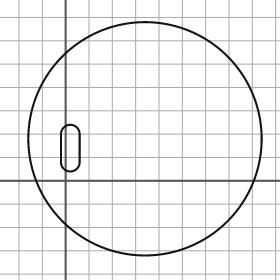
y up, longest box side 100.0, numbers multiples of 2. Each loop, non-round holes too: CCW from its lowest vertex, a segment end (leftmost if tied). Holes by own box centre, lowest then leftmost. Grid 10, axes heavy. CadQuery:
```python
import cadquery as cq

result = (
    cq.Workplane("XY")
    .moveTo(34.0, 18.0)
    .circle(50.0)
    .moveTo(-2.0, 8.0)
    .threePointArc((2.0, 4.0), (6.0, 8.0))
    .lineTo(6.0, 20.0)
    .threePointArc((2.0, 24.0), (-2.0, 20.0))
    .close()
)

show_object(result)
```